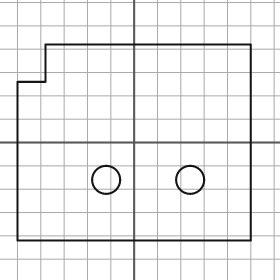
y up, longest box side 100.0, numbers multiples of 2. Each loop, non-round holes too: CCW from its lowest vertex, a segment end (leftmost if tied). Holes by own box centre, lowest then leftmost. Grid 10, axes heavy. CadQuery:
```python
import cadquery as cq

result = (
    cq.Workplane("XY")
    .moveTo(-50.0, -42.0)
    .lineTo(50.0, -42.0)
    .lineTo(50.0, 42.0)
    .lineTo(-38.0, 42.0)
    .lineTo(-38.0, 26.0)
    .lineTo(-50.0, 26.0)
    .close()
    .moveTo(-12.0, -16.0)
    .circle(6.0)
    .moveTo(24.0, -16.0)
    .circle(6.0)
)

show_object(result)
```